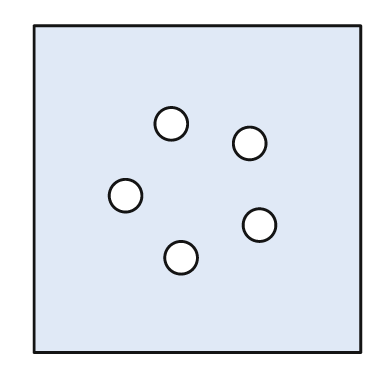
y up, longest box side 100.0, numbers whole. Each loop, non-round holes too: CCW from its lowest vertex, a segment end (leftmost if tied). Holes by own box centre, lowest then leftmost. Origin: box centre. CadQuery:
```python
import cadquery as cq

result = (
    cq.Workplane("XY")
    .moveTo(-50.0, -50.0)
    .lineTo(50.0, -50.0)
    .lineTo(50.0, 50.0)
    .lineTo(-50.0, 50.0)
    .close()
    .moveTo(-5.0, -21.0)
    .circle(5.0)
    .moveTo(19.0, -11.0)
    .circle(5.0)
    .moveTo(-22.0, -2.0)
    .circle(5.0)
    .moveTo(16.0, 14.0)
    .circle(5.0)
    .moveTo(-8.0, 20.0)
    .circle(5.0)
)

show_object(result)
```